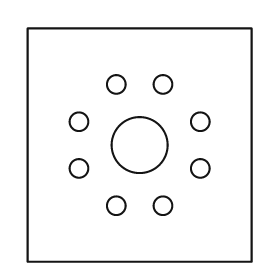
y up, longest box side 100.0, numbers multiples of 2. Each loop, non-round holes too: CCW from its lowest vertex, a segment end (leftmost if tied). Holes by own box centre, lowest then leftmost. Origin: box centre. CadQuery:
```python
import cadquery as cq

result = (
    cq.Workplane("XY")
    .moveTo(-48.0, -50.0)
    .lineTo(48.0, -50.0)
    .lineTo(48.0, 50.0)
    .lineTo(-48.0, 50.0)
    .close()
    .moveTo(-10.0, -26.0)
    .circle(4.0)
    .moveTo(10.0, -26.0)
    .circle(4.0)
    .moveTo(-26.0, -10.0)
    .circle(4.0)
    .moveTo(26.0, -10.0)
    .circle(4.0)
    .moveTo(0.0, 0.0)
    .circle(12.0)
    .moveTo(-26.0, 10.0)
    .circle(4.0)
    .moveTo(26.0, 10.0)
    .circle(4.0)
    .moveTo(-10.0, 26.0)
    .circle(4.0)
    .moveTo(10.0, 26.0)
    .circle(4.0)
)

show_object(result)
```